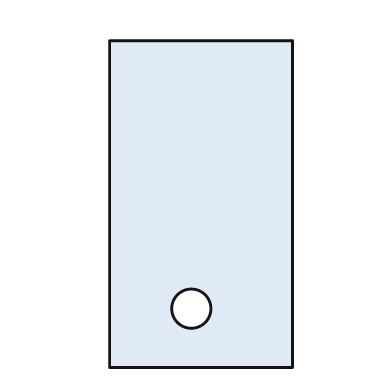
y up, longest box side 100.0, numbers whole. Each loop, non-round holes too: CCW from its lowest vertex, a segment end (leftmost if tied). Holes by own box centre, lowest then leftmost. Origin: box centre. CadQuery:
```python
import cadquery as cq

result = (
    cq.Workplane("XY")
    .moveTo(-28.0, -50.0)
    .lineTo(28.0, -50.0)
    .lineTo(28.0, 50.0)
    .lineTo(-28.0, 50.0)
    .close()
    .moveTo(-3.0, -32.0)
    .circle(6.0)
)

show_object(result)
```